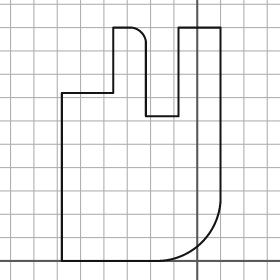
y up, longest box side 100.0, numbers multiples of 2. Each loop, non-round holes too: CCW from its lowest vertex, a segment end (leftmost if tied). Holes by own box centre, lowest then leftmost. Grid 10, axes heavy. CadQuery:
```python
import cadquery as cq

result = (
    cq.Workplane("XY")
    .moveTo(-58.0, 0.0)
    .lineTo(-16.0, 0.0)
    .threePointArc((2.0, 8.0), (10.0, 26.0))
    .lineTo(10.0, 100.0)
    .lineTo(-8.0, 100.0)
    .lineTo(-8.0, 62.0)
    .lineTo(-22.0, 62.0)
    .lineTo(-22.0, 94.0)
    .threePointArc((-24.0, 98.0), (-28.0, 100.0))
    .lineTo(-36.0, 100.0)
    .lineTo(-36.0, 72.0)
    .lineTo(-58.0, 72.0)
    .close()
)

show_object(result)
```